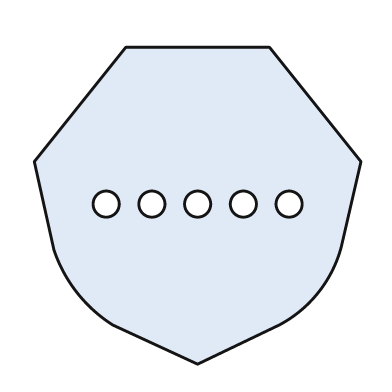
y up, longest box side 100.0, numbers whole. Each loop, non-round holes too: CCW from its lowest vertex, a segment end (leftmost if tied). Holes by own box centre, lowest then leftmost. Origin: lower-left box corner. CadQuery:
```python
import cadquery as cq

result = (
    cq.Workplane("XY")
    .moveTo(50.0, 0.0)
    .lineTo(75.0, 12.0)
    .threePointArc((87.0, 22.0), (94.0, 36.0))
    .lineTo(100.0, 62.0)
    .lineTo(72.0, 97.0)
    .lineTo(28.0, 97.0)
    .lineTo(0.0, 62.0)
    .lineTo(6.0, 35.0)
    .threePointArc((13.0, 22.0), (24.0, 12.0))
    .close()
    .moveTo(22.0, 49.0)
    .circle(4.0)
    .moveTo(36.0, 49.0)
    .circle(4.0)
    .moveTo(50.0, 49.0)
    .circle(4.0)
    .moveTo(64.0, 49.0)
    .circle(4.0)
    .moveTo(78.0, 49.0)
    .circle(4.0)
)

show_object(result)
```